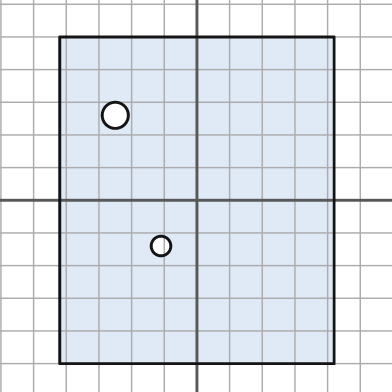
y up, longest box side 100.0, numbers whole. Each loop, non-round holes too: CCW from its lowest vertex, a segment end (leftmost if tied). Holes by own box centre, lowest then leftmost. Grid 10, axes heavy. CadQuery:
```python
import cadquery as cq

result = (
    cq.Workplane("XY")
    .moveTo(-42.0, -50.0)
    .lineTo(42.0, -50.0)
    .lineTo(42.0, 50.0)
    .lineTo(-42.0, 50.0)
    .close()
    .moveTo(-11.0, -14.0)
    .circle(3.0)
    .moveTo(-25.0, 26.0)
    .circle(4.0)
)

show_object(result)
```